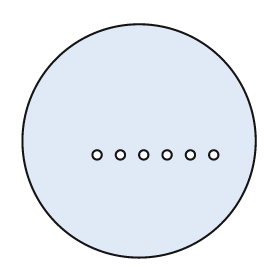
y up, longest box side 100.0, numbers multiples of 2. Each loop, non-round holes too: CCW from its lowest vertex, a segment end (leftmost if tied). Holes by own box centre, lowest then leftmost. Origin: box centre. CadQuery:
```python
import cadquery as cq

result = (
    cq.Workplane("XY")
    .moveTo(0.0, 0.0)
    .circle(50.0)
    .moveTo(-18.0, -6.0)
    .circle(2.0)
    .moveTo(-8.0, -6.0)
    .circle(2.0)
    .moveTo(2.0, -6.0)
    .circle(2.0)
    .moveTo(12.0, -6.0)
    .circle(2.0)
    .moveTo(22.0, -6.0)
    .circle(2.0)
    .moveTo(32.0, -6.0)
    .circle(2.0)
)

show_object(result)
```